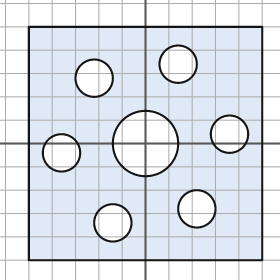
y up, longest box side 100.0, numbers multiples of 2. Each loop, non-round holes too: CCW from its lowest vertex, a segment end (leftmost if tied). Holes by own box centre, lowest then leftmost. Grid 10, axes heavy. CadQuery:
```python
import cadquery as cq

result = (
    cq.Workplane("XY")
    .moveTo(-50.0, -50.0)
    .lineTo(50.0, -50.0)
    .lineTo(50.0, 50.0)
    .lineTo(-50.0, 50.0)
    .close()
    .moveTo(-14.0, -34.0)
    .circle(8.0)
    .moveTo(22.0, -28.0)
    .circle(8.0)
    .moveTo(-36.0, -4.0)
    .circle(8.0)
    .moveTo(0.0, 0.0)
    .circle(14.0)
    .moveTo(36.0, 4.0)
    .circle(8.0)
    .moveTo(-22.0, 28.0)
    .circle(8.0)
    .moveTo(14.0, 34.0)
    .circle(8.0)
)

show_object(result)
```